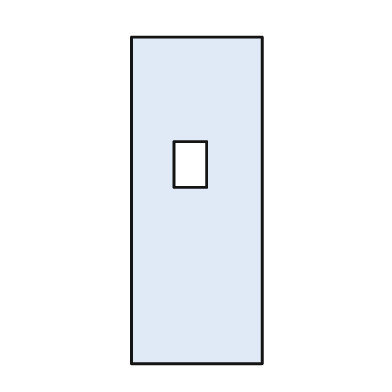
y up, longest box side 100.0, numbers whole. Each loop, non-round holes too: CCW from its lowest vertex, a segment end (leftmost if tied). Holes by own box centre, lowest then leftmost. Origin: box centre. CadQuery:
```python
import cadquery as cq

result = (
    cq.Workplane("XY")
    .moveTo(-20.0, -50.0)
    .lineTo(20.0, -50.0)
    .lineTo(20.0, 50.0)
    .lineTo(-20.0, 50.0)
    .close()
    .moveTo(-7.0, 4.0)
    .lineTo(3.0, 4.0)
    .lineTo(3.0, 18.0)
    .lineTo(-7.0, 18.0)
    .close()
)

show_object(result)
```